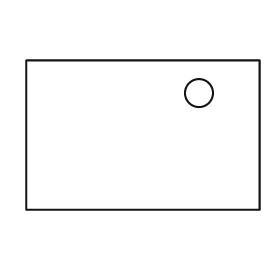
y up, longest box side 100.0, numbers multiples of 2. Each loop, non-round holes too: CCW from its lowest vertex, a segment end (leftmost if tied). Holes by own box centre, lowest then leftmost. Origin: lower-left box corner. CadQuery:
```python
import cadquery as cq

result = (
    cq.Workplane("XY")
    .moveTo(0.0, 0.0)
    .lineTo(100.0, 0.0)
    .lineTo(100.0, 64.0)
    .lineTo(0.0, 64.0)
    .close()
    .moveTo(74.0, 50.0)
    .circle(6.0)
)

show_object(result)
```